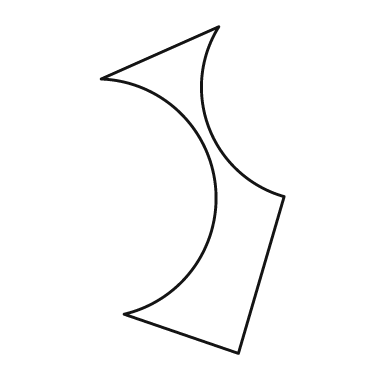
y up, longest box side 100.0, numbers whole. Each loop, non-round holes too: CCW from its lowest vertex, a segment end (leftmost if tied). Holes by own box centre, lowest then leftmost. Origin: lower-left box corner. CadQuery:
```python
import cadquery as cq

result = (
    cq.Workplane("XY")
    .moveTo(42.0, 0.0)
    .lineTo(56.0, 48.0)
    .threePointArc((33.0, 69.0), (36.0, 100.0))
    .lineTo(0.0, 84.0)
    .threePointArc((35.0, 51.0), (7.0, 12.0))
    .close()
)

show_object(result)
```